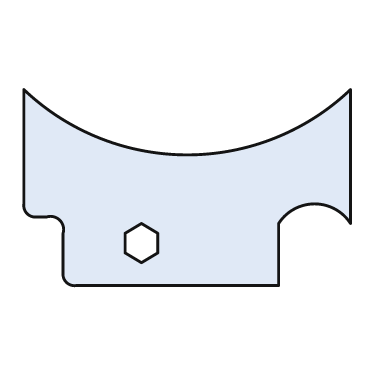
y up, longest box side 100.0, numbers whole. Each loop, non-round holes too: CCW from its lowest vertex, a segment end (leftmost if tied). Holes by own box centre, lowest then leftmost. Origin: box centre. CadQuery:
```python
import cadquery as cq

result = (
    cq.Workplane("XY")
    .moveTo(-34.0, -30.0)
    .lineTo(28.0, -30.0)
    .lineTo(28.0, -11.0)
    .threePointArc((39.0, -5.0), (50.0, -11.0))
    .lineTo(50.0, 30.0)
    .threePointArc((0.0, 10.0), (-50.0, 30.0))
    .lineTo(-50.0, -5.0)
    .threePointArc((-49.0, -8.0), (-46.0, -9.0))
    .lineTo(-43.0, -9.0)
    .threePointArc((-39.0, -10.0), (-38.0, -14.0))
    .lineTo(-38.0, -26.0)
    .threePointArc((-37.0, -29.0), (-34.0, -30.0))
    .close()
    .moveTo(-14.0, -23.0)
    .lineTo(-9.0, -20.0)
    .lineTo(-9.0, -14.0)
    .lineTo(-14.0, -11.0)
    .lineTo(-19.0, -14.0)
    .lineTo(-19.0, -20.0)
    .close()
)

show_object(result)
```